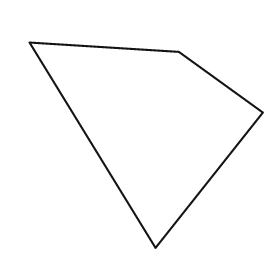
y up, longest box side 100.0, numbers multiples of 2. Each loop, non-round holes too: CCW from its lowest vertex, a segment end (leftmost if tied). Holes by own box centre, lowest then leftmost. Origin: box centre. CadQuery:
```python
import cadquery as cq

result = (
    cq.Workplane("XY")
    .moveTo(4.0, -44.0)
    .lineTo(50.0, 14.0)
    .lineTo(14.0, 40.0)
    .lineTo(-50.0, 44.0)
    .close()
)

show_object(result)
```